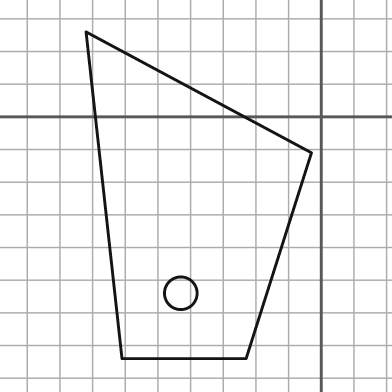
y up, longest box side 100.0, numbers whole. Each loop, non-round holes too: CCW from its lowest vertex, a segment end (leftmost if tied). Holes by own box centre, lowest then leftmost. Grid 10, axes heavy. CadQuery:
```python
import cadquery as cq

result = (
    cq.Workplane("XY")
    .moveTo(-61.0, -74.0)
    .lineTo(-23.0, -74.0)
    .lineTo(-3.0, -11.0)
    .lineTo(-72.0, 26.0)
    .close()
    .moveTo(-43.0, -54.0)
    .circle(5.0)
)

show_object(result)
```